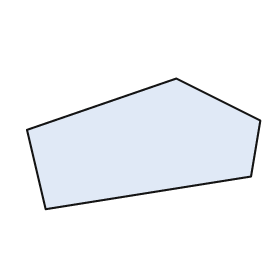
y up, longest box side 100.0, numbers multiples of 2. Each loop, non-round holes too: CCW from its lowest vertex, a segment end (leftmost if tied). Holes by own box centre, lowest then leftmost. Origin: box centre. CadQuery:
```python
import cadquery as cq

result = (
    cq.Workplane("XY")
    .moveTo(-42.0, -28.0)
    .lineTo(46.0, -14.0)
    .lineTo(50.0, 10.0)
    .lineTo(14.0, 28.0)
    .lineTo(-50.0, 6.0)
    .close()
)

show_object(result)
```